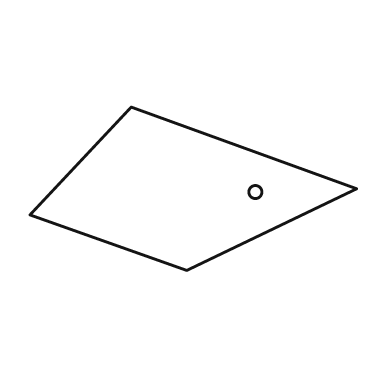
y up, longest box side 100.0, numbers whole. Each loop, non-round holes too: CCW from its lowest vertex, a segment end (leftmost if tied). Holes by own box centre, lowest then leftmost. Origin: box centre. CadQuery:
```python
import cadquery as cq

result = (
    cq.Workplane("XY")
    .moveTo(-2.0, -25.0)
    .lineTo(50.0, 0.0)
    .lineTo(-19.0, 25.0)
    .lineTo(-50.0, -8.0)
    .close()
    .moveTo(19.0, -1.0)
    .circle(2.0)
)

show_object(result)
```